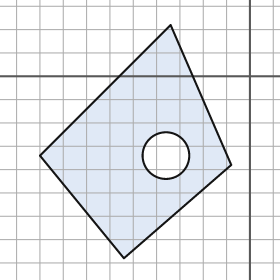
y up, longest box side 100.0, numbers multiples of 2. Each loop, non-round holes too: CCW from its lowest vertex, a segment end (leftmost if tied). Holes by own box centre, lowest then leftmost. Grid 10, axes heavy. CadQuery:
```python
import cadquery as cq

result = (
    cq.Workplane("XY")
    .moveTo(-54.0, -78.0)
    .lineTo(-8.0, -38.0)
    .lineTo(-34.0, 22.0)
    .lineTo(-90.0, -34.0)
    .close()
    .moveTo(-36.0, -34.0)
    .circle(10.0)
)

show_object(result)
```